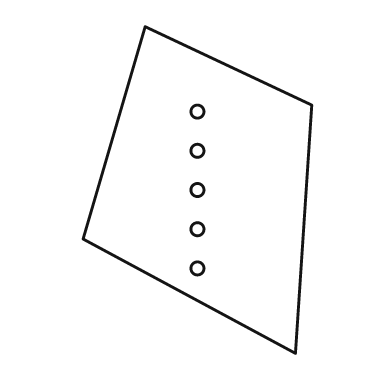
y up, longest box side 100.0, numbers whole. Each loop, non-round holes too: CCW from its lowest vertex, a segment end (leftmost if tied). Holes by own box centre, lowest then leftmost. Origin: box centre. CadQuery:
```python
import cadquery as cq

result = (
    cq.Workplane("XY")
    .moveTo(30.0, -50.0)
    .lineTo(35.0, 26.0)
    .lineTo(-16.0, 50.0)
    .lineTo(-35.0, -15.0)
    .close()
    .moveTo(0.0, -24.0)
    .circle(2.0)
    .moveTo(0.0, -12.0)
    .circle(2.0)
    .moveTo(0.0, 0.0)
    .circle(2.0)
    .moveTo(0.0, 12.0)
    .circle(2.0)
    .moveTo(0.0, 24.0)
    .circle(2.0)
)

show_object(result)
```